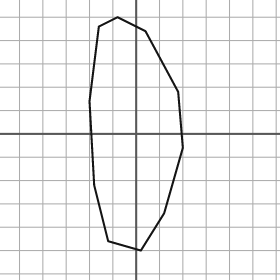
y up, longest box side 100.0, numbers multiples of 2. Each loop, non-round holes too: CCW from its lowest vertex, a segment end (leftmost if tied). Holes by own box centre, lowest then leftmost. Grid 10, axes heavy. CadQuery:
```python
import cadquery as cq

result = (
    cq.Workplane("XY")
    .moveTo(2.0, -50.0)
    .lineTo(12.0, -34.0)
    .lineTo(20.0, -6.0)
    .lineTo(18.0, 18.0)
    .lineTo(4.0, 44.0)
    .lineTo(-8.0, 50.0)
    .lineTo(-16.0, 46.0)
    .lineTo(-20.0, 14.0)
    .lineTo(-18.0, -22.0)
    .lineTo(-12.0, -46.0)
    .close()
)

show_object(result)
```